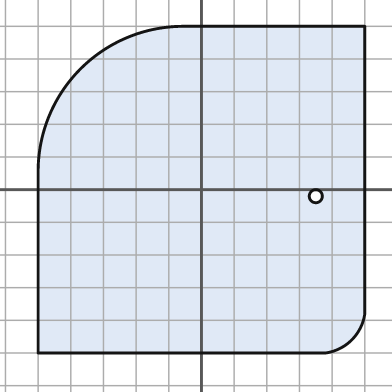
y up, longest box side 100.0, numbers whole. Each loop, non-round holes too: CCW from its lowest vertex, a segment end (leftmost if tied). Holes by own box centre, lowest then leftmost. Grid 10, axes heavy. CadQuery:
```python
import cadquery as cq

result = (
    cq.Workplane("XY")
    .moveTo(-50.0, -50.0)
    .lineTo(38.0, -50.0)
    .threePointArc((46.0, -46.0), (50.0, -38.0))
    .lineTo(50.0, 50.0)
    .lineTo(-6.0, 50.0)
    .threePointArc((-37.0, 37.0), (-50.0, 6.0))
    .close()
    .moveTo(35.0, -2.0)
    .circle(2.0)
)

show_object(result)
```